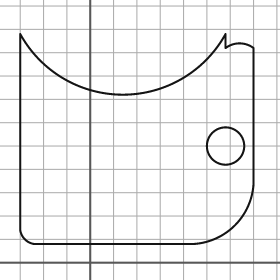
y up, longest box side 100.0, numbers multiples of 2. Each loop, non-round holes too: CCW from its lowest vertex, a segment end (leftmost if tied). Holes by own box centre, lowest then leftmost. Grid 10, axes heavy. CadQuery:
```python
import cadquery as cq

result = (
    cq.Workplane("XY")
    .moveTo(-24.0, 8.0)
    .lineTo(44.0, 8.0)
    .threePointArc((62.0, 16.0), (70.0, 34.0))
    .lineTo(70.0, 92.0)
    .threePointArc((64.0, 94.0), (58.0, 92.0))
    .lineTo(58.0, 98.0)
    .threePointArc((14.0, 72.0), (-30.0, 98.0))
    .lineTo(-30.0, 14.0)
    .threePointArc((-28.0, 10.0), (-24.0, 8.0))
    .close()
    .moveTo(58.0, 50.0)
    .circle(8.0)
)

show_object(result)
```